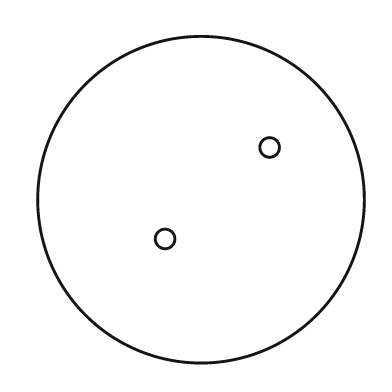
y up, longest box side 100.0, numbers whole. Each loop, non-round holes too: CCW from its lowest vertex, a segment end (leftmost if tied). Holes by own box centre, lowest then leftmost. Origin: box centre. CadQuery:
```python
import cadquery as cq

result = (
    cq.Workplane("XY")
    .moveTo(0.0, 0.0)
    .circle(50.0)
    .moveTo(-11.0, -12.0)
    .circle(3.0)
    .moveTo(21.0, 16.0)
    .circle(3.0)
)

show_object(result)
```